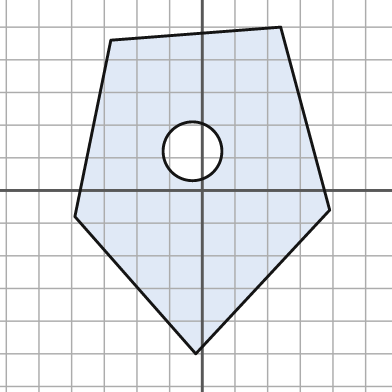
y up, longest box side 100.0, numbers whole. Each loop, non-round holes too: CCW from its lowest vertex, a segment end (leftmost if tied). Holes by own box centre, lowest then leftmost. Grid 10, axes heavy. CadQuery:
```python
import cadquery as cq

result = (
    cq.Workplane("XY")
    .moveTo(-2.0, -50.0)
    .lineTo(39.0, -6.0)
    .lineTo(24.0, 50.0)
    .lineTo(-28.0, 46.0)
    .lineTo(-39.0, -8.0)
    .close()
    .moveTo(-3.0, 12.0)
    .circle(9.0)
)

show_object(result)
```